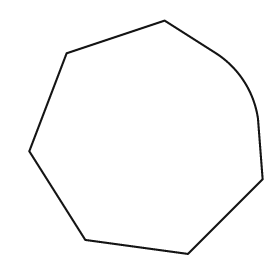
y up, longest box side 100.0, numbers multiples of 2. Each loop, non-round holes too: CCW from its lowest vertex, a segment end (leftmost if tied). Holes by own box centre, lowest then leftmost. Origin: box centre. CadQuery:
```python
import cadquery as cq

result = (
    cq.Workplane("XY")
    .moveTo(18.0, -50.0)
    .lineTo(50.0, -18.0)
    .lineTo(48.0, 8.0)
    .threePointArc((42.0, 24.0), (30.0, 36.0))
    .lineTo(8.0, 50.0)
    .lineTo(-34.0, 36.0)
    .lineTo(-50.0, -6.0)
    .lineTo(-26.0, -44.0)
    .close()
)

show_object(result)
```